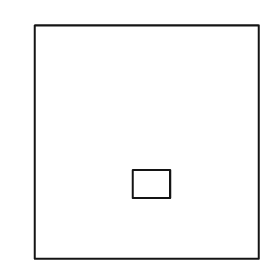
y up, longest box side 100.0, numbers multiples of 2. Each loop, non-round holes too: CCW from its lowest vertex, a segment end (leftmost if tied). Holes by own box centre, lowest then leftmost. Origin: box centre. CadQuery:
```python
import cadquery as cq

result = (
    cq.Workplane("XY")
    .moveTo(-48.0, -50.0)
    .lineTo(48.0, -50.0)
    .lineTo(48.0, 50.0)
    .lineTo(-48.0, 50.0)
    .close()
    .moveTo(-6.0, -24.0)
    .lineTo(10.0, -24.0)
    .lineTo(10.0, -12.0)
    .lineTo(-6.0, -12.0)
    .close()
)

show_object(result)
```